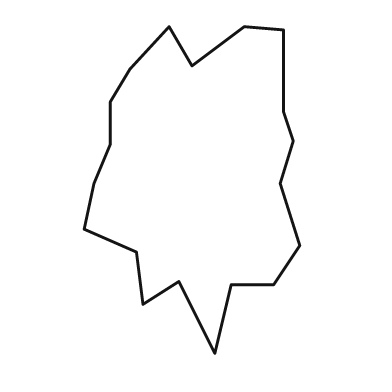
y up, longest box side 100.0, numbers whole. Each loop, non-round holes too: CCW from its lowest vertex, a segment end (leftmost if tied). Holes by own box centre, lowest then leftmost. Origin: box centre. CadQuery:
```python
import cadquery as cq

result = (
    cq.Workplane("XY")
    .moveTo(7.0, -50.0)
    .lineTo(12.0, -29.0)
    .lineTo(25.0, -29.0)
    .lineTo(33.0, -17.0)
    .lineTo(27.0, 2.0)
    .lineTo(31.0, 15.0)
    .lineTo(28.0, 24.0)
    .lineTo(28.0, 49.0)
    .lineTo(16.0, 50.0)
    .lineTo(0.0, 38.0)
    .lineTo(-7.0, 50.0)
    .lineTo(-19.0, 37.0)
    .lineTo(-25.0, 27.0)
    .lineTo(-25.0, 14.0)
    .lineTo(-30.0, 2.0)
    .lineTo(-33.0, -12.0)
    .lineTo(-17.0, -19.0)
    .lineTo(-15.0, -35.0)
    .lineTo(-4.0, -28.0)
    .close()
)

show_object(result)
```